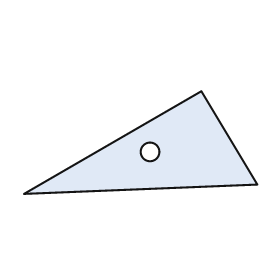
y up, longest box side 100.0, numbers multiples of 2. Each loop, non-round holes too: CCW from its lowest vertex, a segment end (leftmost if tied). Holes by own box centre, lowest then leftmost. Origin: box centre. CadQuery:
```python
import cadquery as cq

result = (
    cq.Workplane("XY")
    .moveTo(-50.0, -22.0)
    .lineTo(50.0, -18.0)
    .lineTo(26.0, 22.0)
    .close()
    .moveTo(4.0, -4.0)
    .circle(4.0)
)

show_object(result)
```